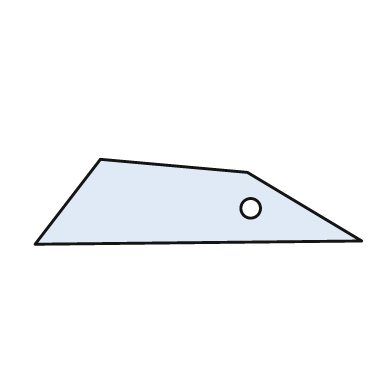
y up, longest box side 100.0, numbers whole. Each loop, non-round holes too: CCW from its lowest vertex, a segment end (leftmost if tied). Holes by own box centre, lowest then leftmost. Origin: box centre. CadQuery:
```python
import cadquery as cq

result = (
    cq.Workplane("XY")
    .moveTo(-50.0, -13.0)
    .lineTo(50.0, -12.0)
    .lineTo(15.0, 9.0)
    .lineTo(-30.0, 13.0)
    .close()
    .moveTo(16.0, -2.0)
    .circle(3.0)
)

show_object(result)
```